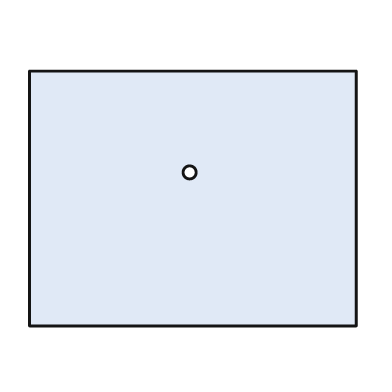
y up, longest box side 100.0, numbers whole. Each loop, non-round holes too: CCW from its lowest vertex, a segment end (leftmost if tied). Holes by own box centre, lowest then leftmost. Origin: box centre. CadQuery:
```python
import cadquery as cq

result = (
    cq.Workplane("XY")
    .moveTo(-50.0, -39.0)
    .lineTo(50.0, -39.0)
    .lineTo(50.0, 39.0)
    .lineTo(-50.0, 39.0)
    .close()
    .moveTo(-1.0, 8.0)
    .circle(2.0)
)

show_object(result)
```